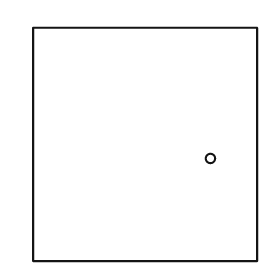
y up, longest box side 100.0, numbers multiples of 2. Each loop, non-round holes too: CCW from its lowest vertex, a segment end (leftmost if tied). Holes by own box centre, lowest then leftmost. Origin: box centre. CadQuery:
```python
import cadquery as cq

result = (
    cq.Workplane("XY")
    .moveTo(-48.0, -50.0)
    .lineTo(48.0, -50.0)
    .lineTo(48.0, 50.0)
    .lineTo(-48.0, 50.0)
    .close()
    .moveTo(28.0, -6.0)
    .circle(2.0)
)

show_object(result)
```